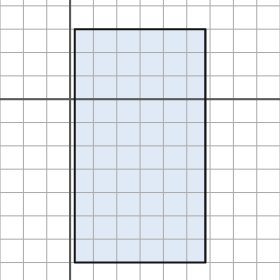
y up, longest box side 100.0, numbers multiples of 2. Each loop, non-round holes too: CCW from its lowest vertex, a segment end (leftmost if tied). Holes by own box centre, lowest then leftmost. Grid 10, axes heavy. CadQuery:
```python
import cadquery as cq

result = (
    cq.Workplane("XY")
    .moveTo(2.0, -70.0)
    .lineTo(58.0, -70.0)
    .lineTo(58.0, 30.0)
    .lineTo(2.0, 30.0)
    .close()
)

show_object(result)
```